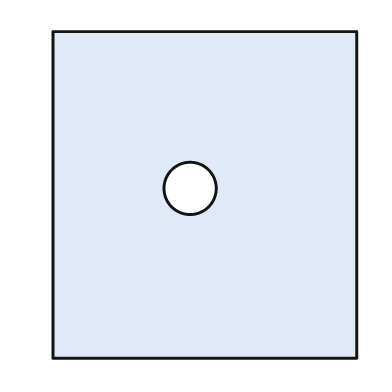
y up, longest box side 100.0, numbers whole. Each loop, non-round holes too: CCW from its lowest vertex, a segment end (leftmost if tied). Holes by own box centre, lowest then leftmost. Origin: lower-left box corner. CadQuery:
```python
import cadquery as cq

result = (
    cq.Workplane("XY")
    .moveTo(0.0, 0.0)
    .lineTo(93.0, 0.0)
    .lineTo(93.0, 100.0)
    .lineTo(0.0, 100.0)
    .close()
    .moveTo(42.0, 52.0)
    .circle(8.0)
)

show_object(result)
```